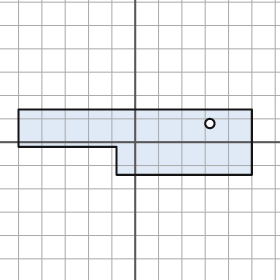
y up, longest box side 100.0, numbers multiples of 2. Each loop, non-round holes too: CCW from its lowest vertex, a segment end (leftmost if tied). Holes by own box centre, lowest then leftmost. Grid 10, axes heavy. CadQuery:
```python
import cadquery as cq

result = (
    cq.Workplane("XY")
    .moveTo(-8.0, -14.0)
    .lineTo(50.0, -14.0)
    .lineTo(50.0, 14.0)
    .lineTo(-50.0, 14.0)
    .lineTo(-50.0, -2.0)
    .lineTo(-8.0, -2.0)
    .close()
    .moveTo(32.0, 8.0)
    .circle(2.0)
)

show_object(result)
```